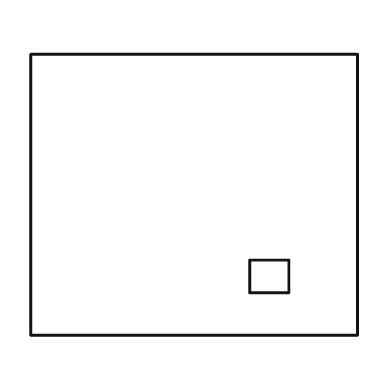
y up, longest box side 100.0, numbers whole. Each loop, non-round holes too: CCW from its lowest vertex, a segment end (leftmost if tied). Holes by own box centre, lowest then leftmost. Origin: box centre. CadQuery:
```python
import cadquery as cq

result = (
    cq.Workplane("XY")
    .moveTo(-50.0, -43.0)
    .lineTo(50.0, -43.0)
    .lineTo(50.0, 43.0)
    .lineTo(-50.0, 43.0)
    .close()
    .moveTo(17.0, -30.0)
    .lineTo(29.0, -30.0)
    .lineTo(29.0, -20.0)
    .lineTo(17.0, -20.0)
    .close()
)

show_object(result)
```